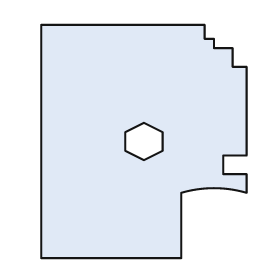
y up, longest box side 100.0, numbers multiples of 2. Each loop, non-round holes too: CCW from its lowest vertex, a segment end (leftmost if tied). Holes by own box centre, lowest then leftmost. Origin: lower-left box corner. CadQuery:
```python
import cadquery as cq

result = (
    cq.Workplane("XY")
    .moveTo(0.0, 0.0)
    .lineTo(60.0, 0.0)
    .lineTo(60.0, 28.0)
    .threePointArc((74.0, 30.0), (88.0, 28.0))
    .lineTo(88.0, 36.0)
    .lineTo(78.0, 36.0)
    .lineTo(78.0, 44.0)
    .lineTo(88.0, 44.0)
    .lineTo(88.0, 82.0)
    .lineTo(82.0, 82.0)
    .lineTo(82.0, 90.0)
    .lineTo(74.0, 90.0)
    .lineTo(74.0, 94.0)
    .lineTo(70.0, 94.0)
    .lineTo(70.0, 100.0)
    .lineTo(0.0, 100.0)
    .close()
    .moveTo(44.0, 42.0)
    .lineTo(52.0, 46.0)
    .lineTo(52.0, 54.0)
    .lineTo(44.0, 58.0)
    .lineTo(36.0, 54.0)
    .lineTo(36.0, 46.0)
    .close()
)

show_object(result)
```